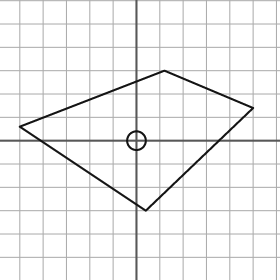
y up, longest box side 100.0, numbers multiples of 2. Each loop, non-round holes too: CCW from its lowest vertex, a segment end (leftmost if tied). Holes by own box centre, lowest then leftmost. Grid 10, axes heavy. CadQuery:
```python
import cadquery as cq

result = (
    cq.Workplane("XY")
    .moveTo(4.0, -30.0)
    .lineTo(50.0, 14.0)
    .lineTo(12.0, 30.0)
    .lineTo(-50.0, 6.0)
    .close()
    .moveTo(0.0, 0.0)
    .circle(4.0)
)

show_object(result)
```